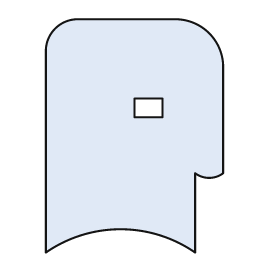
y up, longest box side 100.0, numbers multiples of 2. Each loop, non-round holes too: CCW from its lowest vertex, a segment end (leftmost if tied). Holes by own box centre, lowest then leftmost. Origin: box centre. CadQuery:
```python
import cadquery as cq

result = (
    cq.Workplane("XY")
    .moveTo(-38.0, -50.0)
    .threePointArc((-6.0, -40.0), (26.0, -50.0))
    .lineTo(26.0, -16.0)
    .threePointArc((32.0, -18.0), (38.0, -16.0))
    .lineTo(38.0, 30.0)
    .threePointArc((32.0, 44.0), (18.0, 50.0))
    .lineTo(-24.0, 50.0)
    .threePointArc((-34.0, 46.0), (-38.0, 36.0))
    .close()
    .moveTo(0.0, 8.0)
    .lineTo(12.0, 8.0)
    .lineTo(12.0, 16.0)
    .lineTo(0.0, 16.0)
    .close()
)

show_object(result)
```